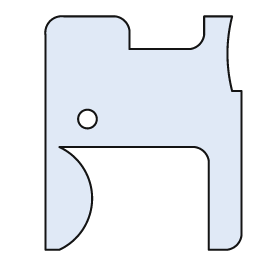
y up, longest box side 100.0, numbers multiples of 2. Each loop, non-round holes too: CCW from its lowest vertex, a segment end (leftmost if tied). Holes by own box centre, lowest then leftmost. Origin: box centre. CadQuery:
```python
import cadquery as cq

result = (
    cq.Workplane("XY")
    .moveTo(-42.0, -50.0)
    .lineTo(-36.0, -50.0)
    .threePointArc((-22.0, -28.0), (-36.0, -6.0))
    .lineTo(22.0, -6.0)
    .threePointArc((26.0, -8.0), (28.0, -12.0))
    .lineTo(28.0, -50.0)
    .lineTo(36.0, -50.0)
    .threePointArc((40.0, -48.0), (42.0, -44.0))
    .lineTo(42.0, 18.0)
    .lineTo(38.0, 18.0)
    .threePointArc((36.0, 34.0), (38.0, 50.0))
    .lineTo(26.0, 50.0)
    .lineTo(26.0, 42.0)
    .threePointArc((24.0, 38.0), (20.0, 36.0))
    .lineTo(-6.0, 36.0)
    .lineTo(-6.0, 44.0)
    .threePointArc((-8.0, 48.0), (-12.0, 50.0))
    .lineTo(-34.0, 50.0)
    .threePointArc((-40.0, 48.0), (-42.0, 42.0))
    .close()
    .moveTo(-24.0, 6.0)
    .circle(4.0)
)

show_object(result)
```